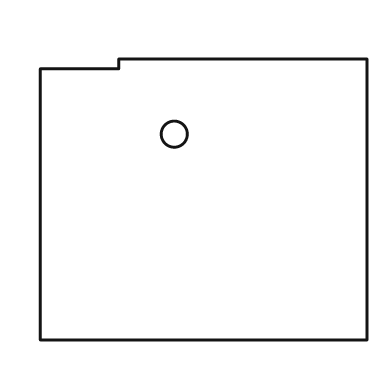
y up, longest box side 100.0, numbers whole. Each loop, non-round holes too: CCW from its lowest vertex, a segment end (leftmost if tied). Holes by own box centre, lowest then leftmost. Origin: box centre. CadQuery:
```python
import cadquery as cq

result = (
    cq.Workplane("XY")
    .moveTo(-50.0, -43.0)
    .lineTo(50.0, -43.0)
    .lineTo(50.0, 43.0)
    .lineTo(-26.0, 43.0)
    .lineTo(-26.0, 40.0)
    .lineTo(-50.0, 40.0)
    .close()
    .moveTo(-9.0, 20.0)
    .circle(4.0)
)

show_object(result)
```